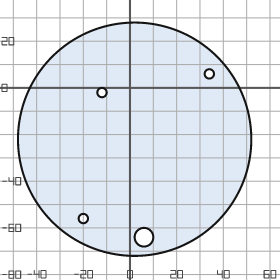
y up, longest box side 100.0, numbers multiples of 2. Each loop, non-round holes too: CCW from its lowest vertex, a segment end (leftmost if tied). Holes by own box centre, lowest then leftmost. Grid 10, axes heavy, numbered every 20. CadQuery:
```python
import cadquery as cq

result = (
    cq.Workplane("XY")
    .moveTo(2.0, -22.0)
    .circle(50.0)
    .moveTo(6.0, -64.0)
    .circle(4.0)
    .moveTo(-20.0, -56.0)
    .circle(2.0)
    .moveTo(-12.0, -2.0)
    .circle(2.0)
    .moveTo(34.0, 6.0)
    .circle(2.0)
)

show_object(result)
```